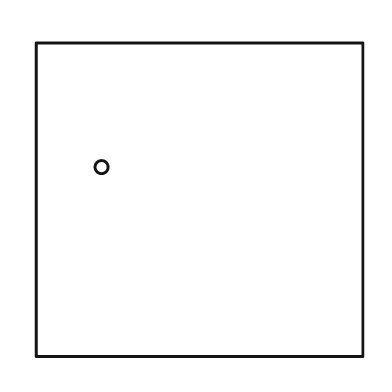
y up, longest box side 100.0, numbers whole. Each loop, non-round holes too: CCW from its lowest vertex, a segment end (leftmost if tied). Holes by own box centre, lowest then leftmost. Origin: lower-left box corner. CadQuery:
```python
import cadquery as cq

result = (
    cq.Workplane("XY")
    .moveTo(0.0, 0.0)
    .lineTo(100.0, 0.0)
    .lineTo(100.0, 96.0)
    .lineTo(0.0, 96.0)
    .close()
    .moveTo(20.0, 58.0)
    .circle(2.0)
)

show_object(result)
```